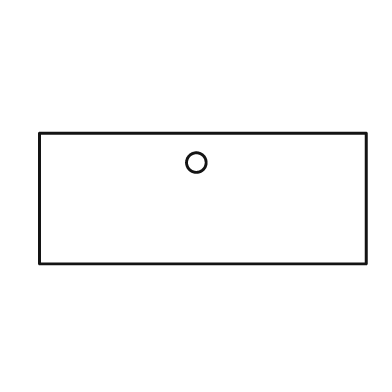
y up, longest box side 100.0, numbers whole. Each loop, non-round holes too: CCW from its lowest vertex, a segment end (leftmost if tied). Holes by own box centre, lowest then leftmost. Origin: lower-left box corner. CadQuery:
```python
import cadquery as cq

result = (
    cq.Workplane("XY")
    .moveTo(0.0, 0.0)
    .lineTo(100.0, 0.0)
    .lineTo(100.0, 40.0)
    .lineTo(0.0, 40.0)
    .close()
    .moveTo(48.0, 31.0)
    .circle(3.0)
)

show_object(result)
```